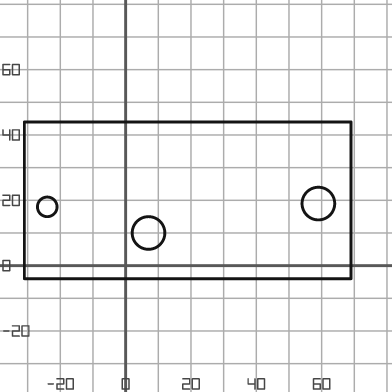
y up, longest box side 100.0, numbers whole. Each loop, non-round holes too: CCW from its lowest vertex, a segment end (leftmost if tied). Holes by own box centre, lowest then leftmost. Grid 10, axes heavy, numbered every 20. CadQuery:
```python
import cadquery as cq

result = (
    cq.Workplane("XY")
    .moveTo(-31.0, -4.0)
    .lineTo(69.0, -4.0)
    .lineTo(69.0, 44.0)
    .lineTo(-31.0, 44.0)
    .close()
    .moveTo(7.0, 10.0)
    .circle(5.0)
    .moveTo(-24.0, 18.0)
    .circle(3.0)
    .moveTo(59.0, 19.0)
    .circle(5.0)
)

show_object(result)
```